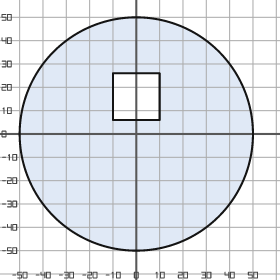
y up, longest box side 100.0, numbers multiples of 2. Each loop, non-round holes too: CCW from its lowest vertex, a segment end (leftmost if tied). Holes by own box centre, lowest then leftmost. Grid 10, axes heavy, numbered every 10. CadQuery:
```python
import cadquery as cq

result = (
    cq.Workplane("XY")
    .moveTo(0.0, 0.0)
    .circle(50.0)
    .moveTo(-10.0, 6.0)
    .lineTo(10.0, 6.0)
    .lineTo(10.0, 26.0)
    .lineTo(-10.0, 26.0)
    .close()
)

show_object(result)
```